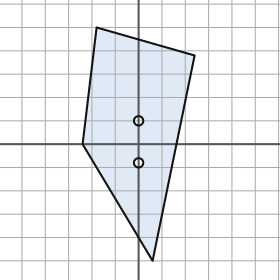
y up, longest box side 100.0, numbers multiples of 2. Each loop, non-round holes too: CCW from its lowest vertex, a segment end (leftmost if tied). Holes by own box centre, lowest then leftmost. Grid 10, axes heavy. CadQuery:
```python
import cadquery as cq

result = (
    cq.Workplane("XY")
    .moveTo(6.0, -50.0)
    .lineTo(24.0, 38.0)
    .lineTo(-18.0, 50.0)
    .lineTo(-24.0, 0.0)
    .close()
    .moveTo(0.0, -8.0)
    .circle(2.0)
    .moveTo(0.0, 10.0)
    .circle(2.0)
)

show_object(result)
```